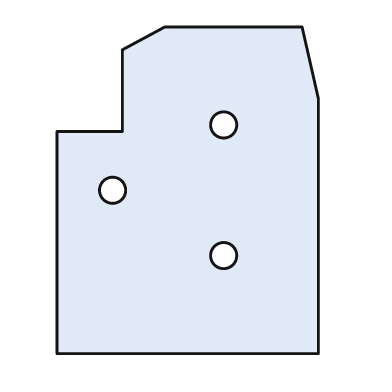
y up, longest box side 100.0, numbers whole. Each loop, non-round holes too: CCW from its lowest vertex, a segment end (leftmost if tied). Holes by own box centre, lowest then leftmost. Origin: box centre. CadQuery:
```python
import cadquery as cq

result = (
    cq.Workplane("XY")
    .moveTo(-40.0, -50.0)
    .lineTo(40.0, -50.0)
    .lineTo(40.0, 28.0)
    .lineTo(35.0, 50.0)
    .lineTo(-7.0, 50.0)
    .lineTo(-20.0, 43.0)
    .lineTo(-20.0, 18.0)
    .lineTo(-40.0, 18.0)
    .close()
    .moveTo(11.0, -20.0)
    .circle(4.0)
    .moveTo(-23.0, 0.0)
    .circle(4.0)
    .moveTo(11.0, 20.0)
    .circle(4.0)
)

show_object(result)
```